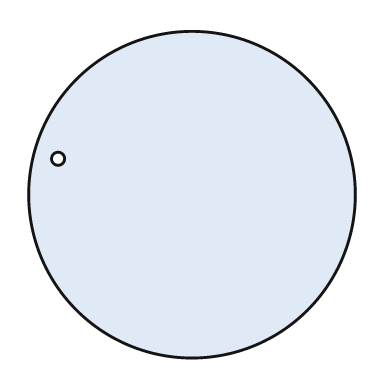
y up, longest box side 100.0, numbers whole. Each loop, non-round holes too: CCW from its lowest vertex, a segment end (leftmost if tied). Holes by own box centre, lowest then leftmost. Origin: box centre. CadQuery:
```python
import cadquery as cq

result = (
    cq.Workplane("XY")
    .moveTo(0.0, 0.0)
    .circle(50.0)
    .moveTo(-41.0, 11.0)
    .circle(2.0)
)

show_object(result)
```